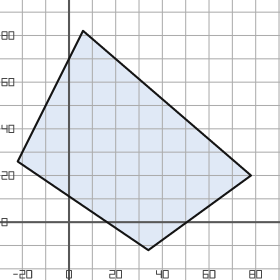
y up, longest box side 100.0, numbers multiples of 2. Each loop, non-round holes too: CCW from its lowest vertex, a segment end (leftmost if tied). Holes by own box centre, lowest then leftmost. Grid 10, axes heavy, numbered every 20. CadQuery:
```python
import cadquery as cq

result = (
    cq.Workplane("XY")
    .moveTo(34.0, -12.0)
    .lineTo(78.0, 20.0)
    .lineTo(6.0, 82.0)
    .lineTo(-22.0, 26.0)
    .close()
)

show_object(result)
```